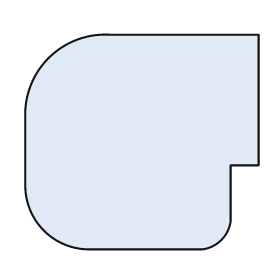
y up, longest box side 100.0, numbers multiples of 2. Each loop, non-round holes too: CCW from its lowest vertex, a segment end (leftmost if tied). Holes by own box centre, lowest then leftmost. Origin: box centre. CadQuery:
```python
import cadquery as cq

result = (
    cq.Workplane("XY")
    .moveTo(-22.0, -46.0)
    .lineTo(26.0, -46.0)
    .threePointArc((34.0, -42.0), (38.0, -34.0))
    .lineTo(38.0, -10.0)
    .lineTo(50.0, -10.0)
    .lineTo(50.0, 46.0)
    .lineTo(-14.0, 46.0)
    .threePointArc((-40.0, 36.0), (-50.0, 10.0))
    .lineTo(-50.0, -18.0)
    .threePointArc((-42.0, -38.0), (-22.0, -46.0))
    .close()
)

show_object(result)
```